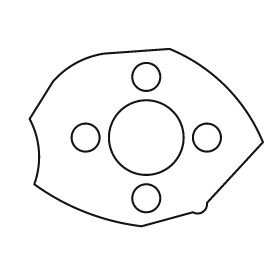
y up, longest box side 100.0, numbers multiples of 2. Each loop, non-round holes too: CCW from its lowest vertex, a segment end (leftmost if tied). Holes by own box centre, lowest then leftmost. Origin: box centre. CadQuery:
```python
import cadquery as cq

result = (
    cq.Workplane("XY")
    .moveTo(-2.0, -38.0)
    .lineTo(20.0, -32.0)
    .threePointArc((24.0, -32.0), (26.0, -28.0))
    .lineTo(50.0, -2.0)
    .threePointArc((34.0, 22.0), (10.0, 38.0))
    .lineTo(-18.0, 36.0)
    .threePointArc((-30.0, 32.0), (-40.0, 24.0))
    .lineTo(-50.0, 8.0)
    .threePointArc((-46.0, -6.0), (-48.0, -20.0))
    .threePointArc((-26.0, -32.0), (-2.0, -38.0))
    .close()
    .moveTo(0.0, -26.0)
    .circle(6.0)
    .moveTo(-26.0, 0.0)
    .circle(6.0)
    .moveTo(0.0, 0.0)
    .circle(16.0)
    .moveTo(26.0, 0.0)
    .circle(6.0)
    .moveTo(0.0, 26.0)
    .circle(6.0)
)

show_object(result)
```